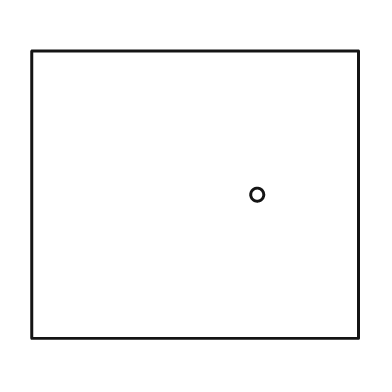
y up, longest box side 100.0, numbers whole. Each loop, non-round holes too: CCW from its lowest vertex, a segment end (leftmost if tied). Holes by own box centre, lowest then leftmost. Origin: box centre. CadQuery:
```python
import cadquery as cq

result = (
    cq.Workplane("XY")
    .moveTo(-50.0, -44.0)
    .lineTo(50.0, -44.0)
    .lineTo(50.0, 44.0)
    .lineTo(-50.0, 44.0)
    .close()
    .moveTo(19.0, 0.0)
    .circle(2.0)
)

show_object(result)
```